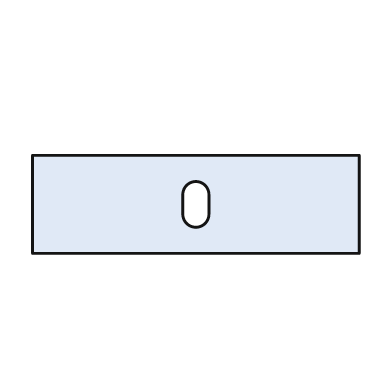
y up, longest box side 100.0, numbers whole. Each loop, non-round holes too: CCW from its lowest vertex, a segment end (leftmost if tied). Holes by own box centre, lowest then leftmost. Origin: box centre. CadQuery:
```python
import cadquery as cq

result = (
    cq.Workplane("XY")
    .moveTo(-50.0, -15.0)
    .lineTo(50.0, -15.0)
    .lineTo(50.0, 15.0)
    .lineTo(-50.0, 15.0)
    .close()
    .moveTo(-4.0, -3.0)
    .threePointArc((0.0, -7.0), (4.0, -3.0))
    .lineTo(4.0, 3.0)
    .threePointArc((0.0, 7.0), (-4.0, 3.0))
    .close()
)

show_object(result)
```